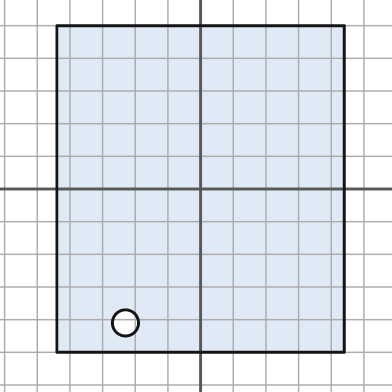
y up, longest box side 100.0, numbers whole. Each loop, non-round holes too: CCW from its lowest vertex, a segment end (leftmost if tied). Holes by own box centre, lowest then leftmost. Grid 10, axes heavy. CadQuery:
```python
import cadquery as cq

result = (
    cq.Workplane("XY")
    .moveTo(-44.0, -50.0)
    .lineTo(44.0, -50.0)
    .lineTo(44.0, 50.0)
    .lineTo(-44.0, 50.0)
    .close()
    .moveTo(-23.0, -41.0)
    .circle(4.0)
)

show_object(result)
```